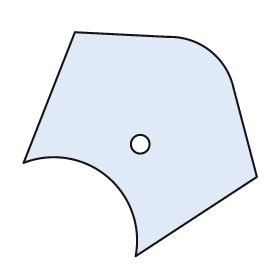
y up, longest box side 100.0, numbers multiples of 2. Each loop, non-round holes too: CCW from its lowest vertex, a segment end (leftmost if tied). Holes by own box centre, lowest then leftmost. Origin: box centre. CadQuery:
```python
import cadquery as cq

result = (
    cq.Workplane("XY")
    .moveTo(-2.0, -48.0)
    .lineTo(50.0, -14.0)
    .lineTo(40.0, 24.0)
    .threePointArc((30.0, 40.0), (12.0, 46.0))
    .lineTo(-28.0, 48.0)
    .lineTo(-50.0, -8.0)
    .threePointArc((-14.0, -14.0), (-2.0, -48.0))
    .close()
    .moveTo(0.0, 0.0)
    .circle(4.0)
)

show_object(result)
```